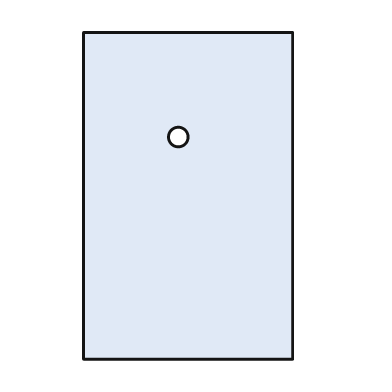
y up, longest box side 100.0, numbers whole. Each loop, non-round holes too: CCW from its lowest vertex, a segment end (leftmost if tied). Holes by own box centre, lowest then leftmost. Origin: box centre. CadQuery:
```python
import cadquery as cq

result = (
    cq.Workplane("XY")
    .moveTo(-32.0, -50.0)
    .lineTo(32.0, -50.0)
    .lineTo(32.0, 50.0)
    .lineTo(-32.0, 50.0)
    .close()
    .moveTo(-3.0, 18.0)
    .circle(3.0)
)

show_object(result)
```